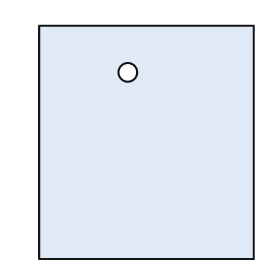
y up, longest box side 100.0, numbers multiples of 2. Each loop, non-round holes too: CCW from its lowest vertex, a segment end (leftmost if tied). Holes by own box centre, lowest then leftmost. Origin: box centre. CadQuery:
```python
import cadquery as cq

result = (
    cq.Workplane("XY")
    .moveTo(-46.0, -50.0)
    .lineTo(46.0, -50.0)
    .lineTo(46.0, 50.0)
    .lineTo(-46.0, 50.0)
    .close()
    .moveTo(-8.0, 30.0)
    .circle(4.0)
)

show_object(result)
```